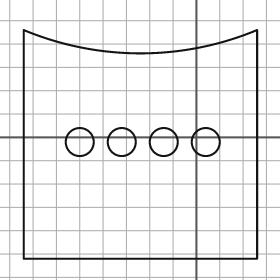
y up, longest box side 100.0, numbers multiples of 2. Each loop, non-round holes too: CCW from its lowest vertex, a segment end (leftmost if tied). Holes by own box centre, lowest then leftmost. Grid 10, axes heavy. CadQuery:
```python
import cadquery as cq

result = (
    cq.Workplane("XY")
    .moveTo(-74.0, -52.0)
    .lineTo(26.0, -52.0)
    .lineTo(26.0, 46.0)
    .threePointArc((-24.0, 36.0), (-74.0, 46.0))
    .close()
    .moveTo(-50.0, -2.0)
    .circle(6.0)
    .moveTo(-32.0, -2.0)
    .circle(6.0)
    .moveTo(-14.0, -2.0)
    .circle(6.0)
    .moveTo(4.0, -2.0)
    .circle(6.0)
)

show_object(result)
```